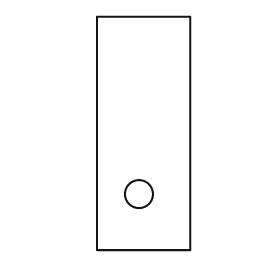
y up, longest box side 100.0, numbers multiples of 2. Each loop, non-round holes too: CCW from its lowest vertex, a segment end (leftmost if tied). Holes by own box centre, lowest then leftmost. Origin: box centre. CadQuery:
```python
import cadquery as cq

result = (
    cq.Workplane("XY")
    .moveTo(-20.0, -50.0)
    .lineTo(20.0, -50.0)
    .lineTo(20.0, 50.0)
    .lineTo(-20.0, 50.0)
    .close()
    .moveTo(-2.0, -26.0)
    .circle(6.0)
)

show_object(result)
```